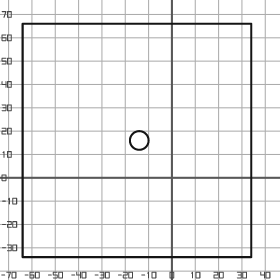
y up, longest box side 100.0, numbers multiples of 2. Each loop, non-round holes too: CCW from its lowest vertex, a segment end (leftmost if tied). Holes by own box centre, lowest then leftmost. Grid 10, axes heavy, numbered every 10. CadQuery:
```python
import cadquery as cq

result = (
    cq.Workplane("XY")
    .moveTo(-64.0, -34.0)
    .lineTo(34.0, -34.0)
    .lineTo(34.0, 66.0)
    .lineTo(-64.0, 66.0)
    .close()
    .moveTo(-14.0, 16.0)
    .circle(4.0)
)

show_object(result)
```